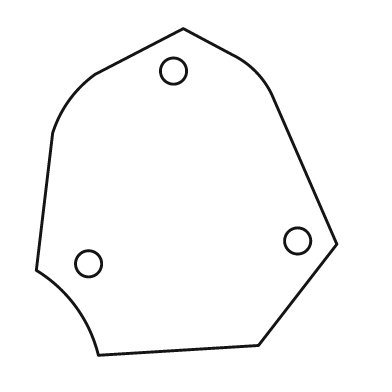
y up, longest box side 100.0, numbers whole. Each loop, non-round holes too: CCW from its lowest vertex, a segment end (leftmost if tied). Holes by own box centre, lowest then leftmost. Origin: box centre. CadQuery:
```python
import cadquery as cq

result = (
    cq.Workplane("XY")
    .moveTo(-27.0, -50.0)
    .lineTo(22.0, -47.0)
    .lineTo(46.0, -16.0)
    .lineTo(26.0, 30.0)
    .threePointArc((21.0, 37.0), (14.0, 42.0))
    .lineTo(-1.0, 50.0)
    .lineTo(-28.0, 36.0)
    .threePointArc((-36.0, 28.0), (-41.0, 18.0))
    .lineTo(-46.0, -24.0)
    .threePointArc((-34.0, -35.0), (-27.0, -50.0))
    .close()
    .moveTo(-30.0, -22.0)
    .circle(4.0)
    .moveTo(34.0, -15.0)
    .circle(4.0)
    .moveTo(-4.0, 37.0)
    .circle(4.0)
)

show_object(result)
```